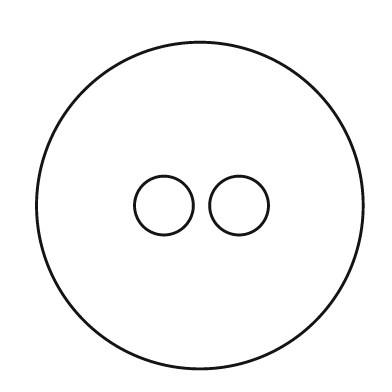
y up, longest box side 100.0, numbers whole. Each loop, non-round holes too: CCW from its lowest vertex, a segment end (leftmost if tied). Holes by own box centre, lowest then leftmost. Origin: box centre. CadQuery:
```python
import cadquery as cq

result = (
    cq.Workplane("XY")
    .moveTo(0.0, 0.0)
    .circle(50.0)
    .moveTo(-11.0, 0.0)
    .circle(9.0)
    .moveTo(12.0, 0.0)
    .circle(9.0)
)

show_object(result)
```